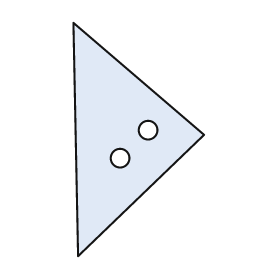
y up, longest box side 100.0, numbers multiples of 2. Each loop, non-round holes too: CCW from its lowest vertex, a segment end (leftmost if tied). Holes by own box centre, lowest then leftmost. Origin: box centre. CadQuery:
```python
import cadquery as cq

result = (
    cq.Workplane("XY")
    .moveTo(-26.0, -50.0)
    .lineTo(28.0, 2.0)
    .lineTo(-28.0, 50.0)
    .close()
    .moveTo(-8.0, -8.0)
    .circle(4.0)
    .moveTo(4.0, 4.0)
    .circle(4.0)
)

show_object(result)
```